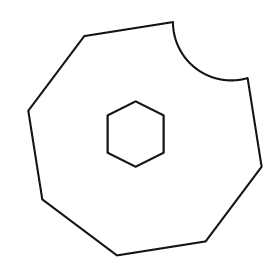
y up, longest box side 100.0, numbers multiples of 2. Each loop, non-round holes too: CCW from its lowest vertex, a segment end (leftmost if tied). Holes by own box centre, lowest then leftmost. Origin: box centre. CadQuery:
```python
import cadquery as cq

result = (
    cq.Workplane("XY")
    .moveTo(-12.0, -50.0)
    .lineTo(26.0, -44.0)
    .lineTo(50.0, -12.0)
    .lineTo(44.0, 26.0)
    .threePointArc((22.0, 30.0), (12.0, 50.0))
    .lineTo(-26.0, 44.0)
    .lineTo(-50.0, 12.0)
    .lineTo(-44.0, -26.0)
    .close()
    .moveTo(-4.0, -12.0)
    .lineTo(8.0, -6.0)
    .lineTo(8.0, 10.0)
    .lineTo(-4.0, 16.0)
    .lineTo(-16.0, 10.0)
    .lineTo(-16.0, -6.0)
    .close()
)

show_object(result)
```